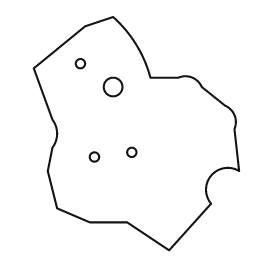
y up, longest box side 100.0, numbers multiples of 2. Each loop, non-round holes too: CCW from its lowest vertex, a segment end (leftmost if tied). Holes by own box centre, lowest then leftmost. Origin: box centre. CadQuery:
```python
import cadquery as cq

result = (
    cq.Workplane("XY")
    .moveTo(14.0, -50.0)
    .lineTo(32.0, -30.0)
    .threePointArc((32.0, -18.0), (44.0, -16.0))
    .lineTo(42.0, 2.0)
    .threePointArc((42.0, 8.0), (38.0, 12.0))
    .lineTo(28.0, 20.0)
    .threePointArc((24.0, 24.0), (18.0, 24.0))
    .lineTo(6.0, 24.0)
    .threePointArc((0.0, 38.0), (-10.0, 50.0))
    .lineTo(-22.0, 46.0)
    .lineTo(-44.0, 28.0)
    .lineTo(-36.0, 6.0)
    .threePointArc((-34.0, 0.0), (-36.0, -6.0))
    .lineTo(-38.0, -16.0)
    .lineTo(-34.0, -32.0)
    .lineTo(-20.0, -38.0)
    .lineTo(-4.0, -38.0)
    .close()
    .moveTo(-18.0, -10.0)
    .circle(2.0)
    .moveTo(-2.0, -8.0)
    .circle(2.0)
    .moveTo(-10.0, 20.0)
    .circle(4.0)
    .moveTo(-24.0, 30.0)
    .circle(2.0)
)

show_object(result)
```